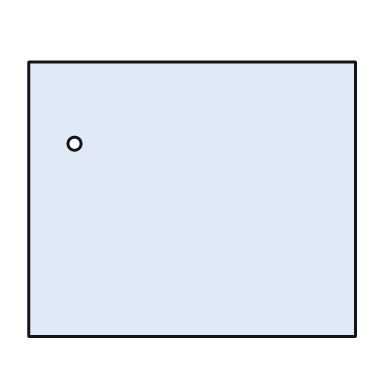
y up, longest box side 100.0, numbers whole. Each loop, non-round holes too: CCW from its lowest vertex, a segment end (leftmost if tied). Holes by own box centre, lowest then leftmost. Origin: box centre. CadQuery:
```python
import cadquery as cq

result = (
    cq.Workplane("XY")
    .moveTo(-50.0, -42.0)
    .lineTo(50.0, -42.0)
    .lineTo(50.0, 42.0)
    .lineTo(-50.0, 42.0)
    .close()
    .moveTo(-36.0, 17.0)
    .circle(2.0)
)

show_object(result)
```